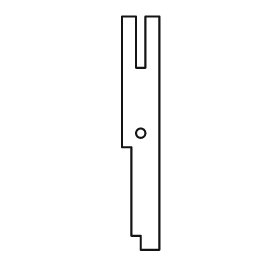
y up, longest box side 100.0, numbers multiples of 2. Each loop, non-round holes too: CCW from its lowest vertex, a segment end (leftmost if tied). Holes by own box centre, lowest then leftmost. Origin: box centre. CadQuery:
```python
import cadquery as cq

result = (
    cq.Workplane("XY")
    .moveTo(0.0, -50.0)
    .lineTo(8.0, -50.0)
    .lineTo(8.0, 50.0)
    .lineTo(2.0, 50.0)
    .lineTo(2.0, 28.0)
    .lineTo(-2.0, 28.0)
    .lineTo(-2.0, 50.0)
    .lineTo(-8.0, 50.0)
    .lineTo(-8.0, -6.0)
    .lineTo(-4.0, -6.0)
    .lineTo(-4.0, -44.0)
    .lineTo(0.0, -44.0)
    .close()
    .moveTo(0.0, 0.0)
    .circle(2.0)
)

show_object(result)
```